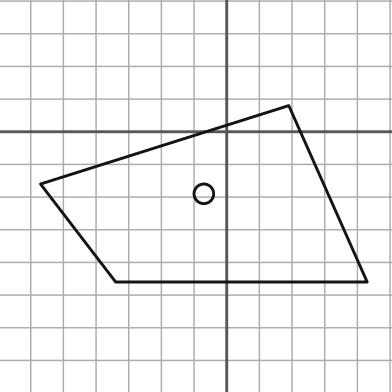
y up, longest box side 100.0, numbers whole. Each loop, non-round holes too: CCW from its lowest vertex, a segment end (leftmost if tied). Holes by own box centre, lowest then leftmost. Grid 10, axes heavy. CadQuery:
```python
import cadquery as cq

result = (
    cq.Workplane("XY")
    .moveTo(-34.0, -46.0)
    .lineTo(43.0, -46.0)
    .lineTo(19.0, 8.0)
    .lineTo(-57.0, -16.0)
    .close()
    .moveTo(-7.0, -19.0)
    .circle(3.0)
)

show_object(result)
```